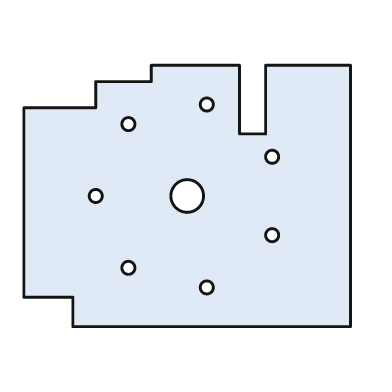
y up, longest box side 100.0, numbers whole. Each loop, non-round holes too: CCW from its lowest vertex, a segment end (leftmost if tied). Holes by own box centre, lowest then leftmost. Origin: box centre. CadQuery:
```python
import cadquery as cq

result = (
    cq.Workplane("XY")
    .moveTo(-35.0, -40.0)
    .lineTo(50.0, -40.0)
    .lineTo(50.0, 40.0)
    .lineTo(24.0, 40.0)
    .lineTo(24.0, 19.0)
    .lineTo(16.0, 19.0)
    .lineTo(16.0, 40.0)
    .lineTo(-11.0, 40.0)
    .lineTo(-11.0, 35.0)
    .lineTo(-28.0, 35.0)
    .lineTo(-28.0, 27.0)
    .lineTo(-50.0, 27.0)
    .lineTo(-50.0, -31.0)
    .lineTo(-35.0, -31.0)
    .close()
    .moveTo(6.0, -28.0)
    .circle(2.0)
    .moveTo(-18.0, -22.0)
    .circle(2.0)
    .moveTo(26.0, -12.0)
    .circle(2.0)
    .moveTo(-28.0, 0.0)
    .circle(2.0)
    .moveTo(0.0, 0.0)
    .circle(5.0)
    .moveTo(26.0, 12.0)
    .circle(2.0)
    .moveTo(-18.0, 22.0)
    .circle(2.0)
    .moveTo(6.0, 28.0)
    .circle(2.0)
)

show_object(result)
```